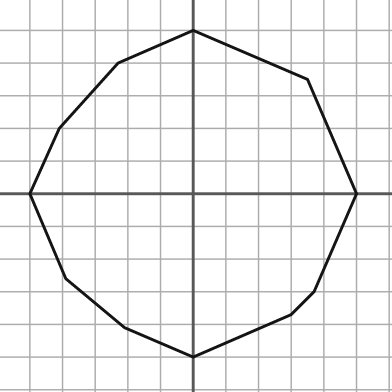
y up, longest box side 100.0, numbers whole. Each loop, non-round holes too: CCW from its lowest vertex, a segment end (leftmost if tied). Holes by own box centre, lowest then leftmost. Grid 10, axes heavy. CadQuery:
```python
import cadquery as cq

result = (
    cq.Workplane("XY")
    .moveTo(0.0, -50.0)
    .lineTo(30.0, -37.0)
    .lineTo(37.0, -30.0)
    .lineTo(50.0, 0.0)
    .lineTo(35.0, 35.0)
    .lineTo(0.0, 50.0)
    .lineTo(-23.0, 40.0)
    .lineTo(-41.0, 20.0)
    .lineTo(-50.0, 0.0)
    .lineTo(-39.0, -26.0)
    .lineTo(-21.0, -41.0)
    .close()
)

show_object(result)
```